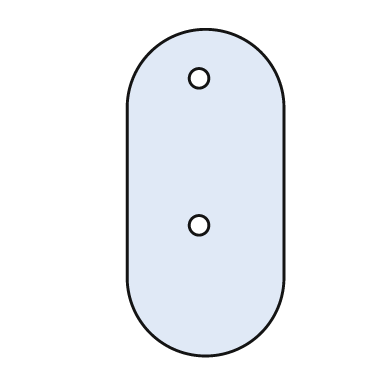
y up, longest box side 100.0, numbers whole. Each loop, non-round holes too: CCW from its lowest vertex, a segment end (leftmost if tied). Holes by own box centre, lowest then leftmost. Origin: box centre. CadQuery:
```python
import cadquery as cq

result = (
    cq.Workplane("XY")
    .moveTo(-24.0, -26.0)
    .threePointArc((0.0, -50.0), (24.0, -26.0))
    .lineTo(24.0, 26.0)
    .threePointArc((0.0, 50.0), (-24.0, 26.0))
    .close()
    .moveTo(-2.0, -10.0)
    .circle(3.0)
    .moveTo(-2.0, 35.0)
    .circle(3.0)
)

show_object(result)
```